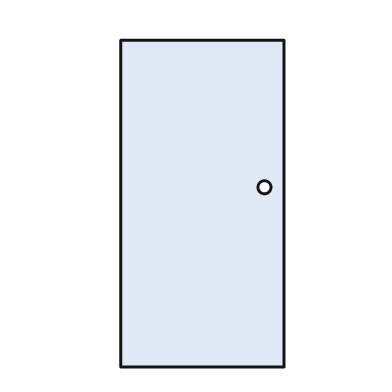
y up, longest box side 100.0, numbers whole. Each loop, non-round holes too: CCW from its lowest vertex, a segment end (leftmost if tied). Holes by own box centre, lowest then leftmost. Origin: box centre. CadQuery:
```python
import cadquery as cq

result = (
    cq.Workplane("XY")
    .moveTo(-25.0, -50.0)
    .lineTo(25.0, -50.0)
    .lineTo(25.0, 50.0)
    .lineTo(-25.0, 50.0)
    .close()
    .moveTo(19.0, 5.0)
    .circle(2.0)
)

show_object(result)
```